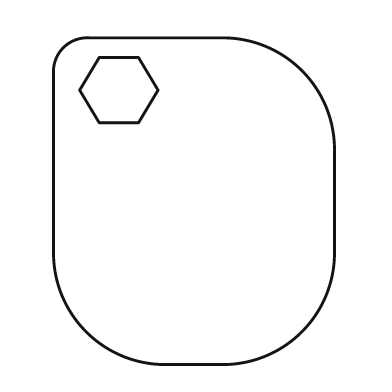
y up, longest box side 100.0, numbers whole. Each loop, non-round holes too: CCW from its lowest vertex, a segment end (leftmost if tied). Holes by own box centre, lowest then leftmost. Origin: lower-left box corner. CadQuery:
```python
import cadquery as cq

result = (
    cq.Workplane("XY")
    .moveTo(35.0, 0.0)
    .lineTo(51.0, 0.0)
    .threePointArc((76.0, 10.0), (86.0, 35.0))
    .lineTo(86.0, 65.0)
    .threePointArc((76.0, 90.0), (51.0, 100.0))
    .lineTo(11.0, 100.0)
    .threePointArc((3.0, 97.0), (0.0, 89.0))
    .lineTo(0.0, 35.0)
    .threePointArc((10.0, 10.0), (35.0, 0.0))
    .close()
    .moveTo(14.0, 74.0)
    .lineTo(26.0, 74.0)
    .lineTo(32.0, 84.0)
    .lineTo(26.0, 94.0)
    .lineTo(14.0, 94.0)
    .lineTo(8.0, 84.0)
    .close()
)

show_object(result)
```